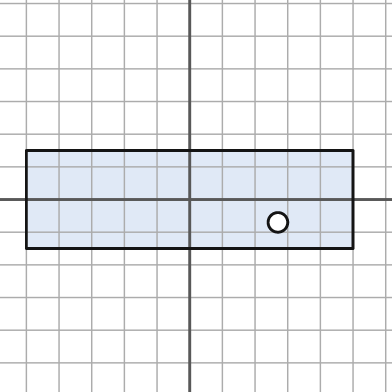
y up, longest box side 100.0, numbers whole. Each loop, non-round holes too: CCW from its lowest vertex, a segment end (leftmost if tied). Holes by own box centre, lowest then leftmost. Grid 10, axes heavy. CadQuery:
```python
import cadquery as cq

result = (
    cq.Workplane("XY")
    .moveTo(-50.0, -15.0)
    .lineTo(50.0, -15.0)
    .lineTo(50.0, 15.0)
    .lineTo(-50.0, 15.0)
    .close()
    .moveTo(27.0, -7.0)
    .circle(3.0)
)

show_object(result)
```